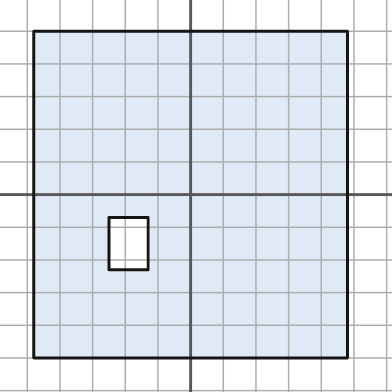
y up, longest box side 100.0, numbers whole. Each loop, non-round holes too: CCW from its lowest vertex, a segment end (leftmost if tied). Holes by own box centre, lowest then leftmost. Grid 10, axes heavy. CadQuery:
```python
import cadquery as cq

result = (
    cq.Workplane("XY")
    .moveTo(-48.0, -50.0)
    .lineTo(48.0, -50.0)
    .lineTo(48.0, 50.0)
    .lineTo(-48.0, 50.0)
    .close()
    .moveTo(-25.0, -23.0)
    .lineTo(-13.0, -23.0)
    .lineTo(-13.0, -7.0)
    .lineTo(-25.0, -7.0)
    .close()
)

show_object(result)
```